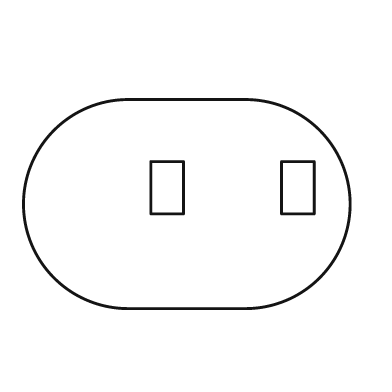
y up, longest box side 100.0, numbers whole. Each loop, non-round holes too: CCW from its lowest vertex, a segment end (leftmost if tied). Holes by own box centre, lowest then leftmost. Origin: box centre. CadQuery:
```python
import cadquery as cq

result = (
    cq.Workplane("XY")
    .moveTo(-18.0, -32.0)
    .lineTo(18.0, -32.0)
    .threePointArc((50.0, 0.0), (18.0, 32.0))
    .lineTo(-18.0, 32.0)
    .threePointArc((-50.0, 0.0), (-18.0, -32.0))
    .close()
    .moveTo(-11.0, -3.0)
    .lineTo(-1.0, -3.0)
    .lineTo(-1.0, 13.0)
    .lineTo(-11.0, 13.0)
    .close()
    .moveTo(29.0, -3.0)
    .lineTo(39.0, -3.0)
    .lineTo(39.0, 13.0)
    .lineTo(29.0, 13.0)
    .close()
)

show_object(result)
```